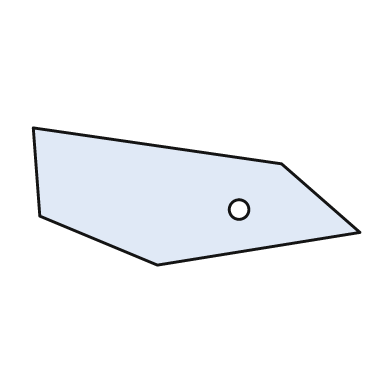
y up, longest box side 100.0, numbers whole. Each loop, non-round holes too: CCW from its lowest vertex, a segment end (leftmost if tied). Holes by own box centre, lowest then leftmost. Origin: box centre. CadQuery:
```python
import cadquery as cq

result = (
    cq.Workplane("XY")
    .moveTo(-12.0, -21.0)
    .lineTo(50.0, -11.0)
    .lineTo(26.0, 10.0)
    .lineTo(-50.0, 21.0)
    .lineTo(-48.0, -6.0)
    .close()
    .moveTo(13.0, -4.0)
    .circle(3.0)
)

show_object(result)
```